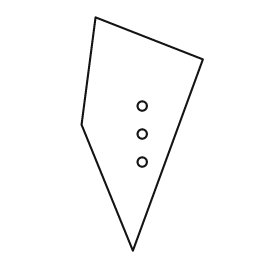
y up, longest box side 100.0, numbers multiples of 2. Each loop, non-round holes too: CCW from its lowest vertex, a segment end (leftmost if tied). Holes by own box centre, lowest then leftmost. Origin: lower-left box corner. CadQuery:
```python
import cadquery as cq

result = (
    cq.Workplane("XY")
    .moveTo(22.0, 0.0)
    .lineTo(52.0, 82.0)
    .lineTo(6.0, 100.0)
    .lineTo(0.0, 54.0)
    .close()
    .moveTo(26.0, 38.0)
    .circle(2.0)
    .moveTo(26.0, 50.0)
    .circle(2.0)
    .moveTo(26.0, 62.0)
    .circle(2.0)
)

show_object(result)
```